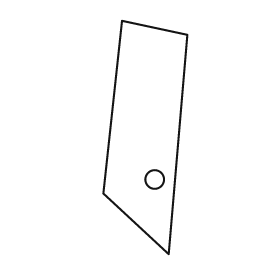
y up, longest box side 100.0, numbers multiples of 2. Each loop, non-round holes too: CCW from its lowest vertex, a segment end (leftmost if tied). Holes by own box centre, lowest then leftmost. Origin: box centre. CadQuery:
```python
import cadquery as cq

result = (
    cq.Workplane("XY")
    .moveTo(10.0, -50.0)
    .lineTo(18.0, 44.0)
    .lineTo(-10.0, 50.0)
    .lineTo(-18.0, -24.0)
    .close()
    .moveTo(4.0, -18.0)
    .circle(4.0)
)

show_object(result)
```